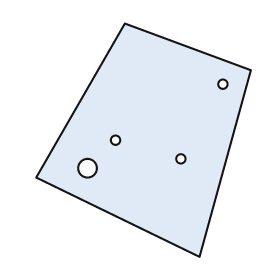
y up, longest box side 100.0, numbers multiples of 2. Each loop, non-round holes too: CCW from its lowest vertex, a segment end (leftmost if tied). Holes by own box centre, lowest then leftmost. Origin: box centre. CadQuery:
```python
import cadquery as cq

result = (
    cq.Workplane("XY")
    .moveTo(24.0, -50.0)
    .lineTo(46.0, 30.0)
    .lineTo(-8.0, 50.0)
    .lineTo(-46.0, -16.0)
    .close()
    .moveTo(-24.0, -12.0)
    .circle(4.0)
    .moveTo(16.0, -8.0)
    .circle(2.0)
    .moveTo(-12.0, 0.0)
    .circle(2.0)
    .moveTo(34.0, 24.0)
    .circle(2.0)
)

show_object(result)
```